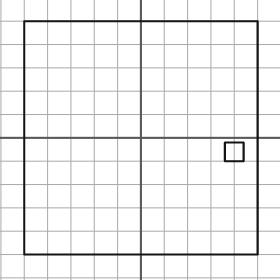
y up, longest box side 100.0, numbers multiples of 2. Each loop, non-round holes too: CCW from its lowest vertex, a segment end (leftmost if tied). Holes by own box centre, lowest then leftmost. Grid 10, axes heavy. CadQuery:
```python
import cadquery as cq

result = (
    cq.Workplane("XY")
    .moveTo(-50.0, -50.0)
    .lineTo(50.0, -50.0)
    .lineTo(50.0, 50.0)
    .lineTo(-50.0, 50.0)
    .close()
    .moveTo(36.0, -10.0)
    .lineTo(44.0, -10.0)
    .lineTo(44.0, -2.0)
    .lineTo(36.0, -2.0)
    .close()
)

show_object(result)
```